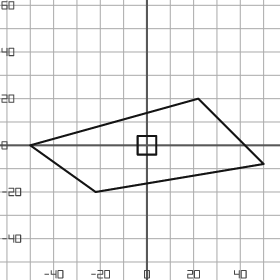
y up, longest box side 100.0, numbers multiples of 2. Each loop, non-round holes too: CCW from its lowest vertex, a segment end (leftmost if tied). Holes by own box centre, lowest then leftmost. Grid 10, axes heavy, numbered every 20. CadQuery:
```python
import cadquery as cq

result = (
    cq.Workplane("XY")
    .moveTo(-22.0, -20.0)
    .lineTo(50.0, -8.0)
    .lineTo(22.0, 20.0)
    .lineTo(-50.0, 0.0)
    .close()
    .moveTo(-4.0, -4.0)
    .lineTo(4.0, -4.0)
    .lineTo(4.0, 4.0)
    .lineTo(-4.0, 4.0)
    .close()
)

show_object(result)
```